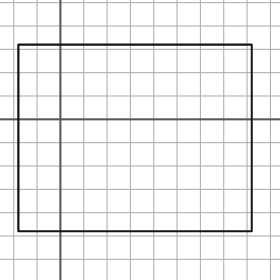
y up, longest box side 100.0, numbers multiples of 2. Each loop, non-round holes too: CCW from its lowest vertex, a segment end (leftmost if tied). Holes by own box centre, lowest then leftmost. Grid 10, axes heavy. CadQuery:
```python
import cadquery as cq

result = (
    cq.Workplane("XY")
    .moveTo(-18.0, -48.0)
    .lineTo(82.0, -48.0)
    .lineTo(82.0, 32.0)
    .lineTo(-18.0, 32.0)
    .close()
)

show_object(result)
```